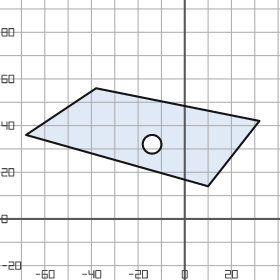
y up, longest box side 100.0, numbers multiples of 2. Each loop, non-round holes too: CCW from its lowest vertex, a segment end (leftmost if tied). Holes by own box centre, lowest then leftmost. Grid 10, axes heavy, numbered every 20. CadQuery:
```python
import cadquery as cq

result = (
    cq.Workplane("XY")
    .moveTo(10.0, 14.0)
    .lineTo(32.0, 42.0)
    .lineTo(-38.0, 56.0)
    .lineTo(-68.0, 36.0)
    .close()
    .moveTo(-14.0, 32.0)
    .circle(4.0)
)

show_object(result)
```